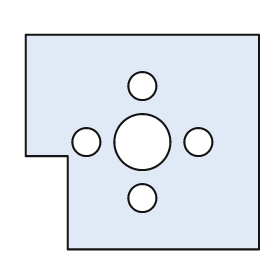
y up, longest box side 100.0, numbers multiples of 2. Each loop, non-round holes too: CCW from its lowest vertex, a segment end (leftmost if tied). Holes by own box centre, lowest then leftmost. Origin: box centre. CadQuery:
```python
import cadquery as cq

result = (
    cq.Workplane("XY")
    .moveTo(-32.0, -46.0)
    .lineTo(50.0, -46.0)
    .lineTo(50.0, 46.0)
    .lineTo(-50.0, 46.0)
    .lineTo(-50.0, -6.0)
    .lineTo(-32.0, -6.0)
    .close()
    .moveTo(0.0, -24.0)
    .circle(6.0)
    .moveTo(-24.0, 0.0)
    .circle(6.0)
    .moveTo(0.0, 0.0)
    .circle(12.0)
    .moveTo(24.0, 0.0)
    .circle(6.0)
    .moveTo(0.0, 24.0)
    .circle(6.0)
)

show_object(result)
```